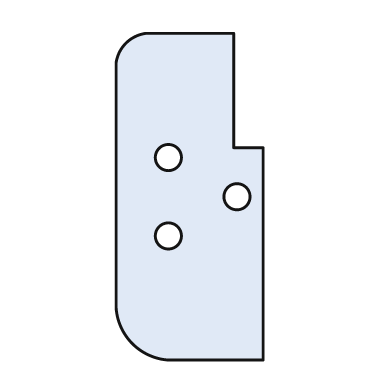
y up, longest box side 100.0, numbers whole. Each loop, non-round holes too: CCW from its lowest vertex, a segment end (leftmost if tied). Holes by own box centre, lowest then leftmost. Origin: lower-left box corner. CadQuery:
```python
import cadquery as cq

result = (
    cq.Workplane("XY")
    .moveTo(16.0, 0.0)
    .lineTo(45.0, 0.0)
    .lineTo(45.0, 65.0)
    .lineTo(36.0, 65.0)
    .lineTo(36.0, 100.0)
    .lineTo(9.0, 100.0)
    .threePointArc((3.0, 97.0), (0.0, 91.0))
    .lineTo(0.0, 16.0)
    .threePointArc((5.0, 5.0), (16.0, 0.0))
    .close()
    .moveTo(16.0, 38.0)
    .circle(4.0)
    .moveTo(37.0, 50.0)
    .circle(4.0)
    .moveTo(16.0, 62.0)
    .circle(4.0)
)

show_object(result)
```